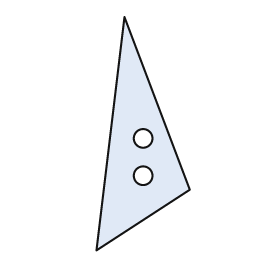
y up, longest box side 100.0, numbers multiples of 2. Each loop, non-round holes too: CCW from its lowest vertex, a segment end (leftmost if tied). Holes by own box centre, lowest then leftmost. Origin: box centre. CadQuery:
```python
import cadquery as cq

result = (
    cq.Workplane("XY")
    .moveTo(-20.0, -50.0)
    .lineTo(20.0, -24.0)
    .lineTo(-8.0, 50.0)
    .close()
    .moveTo(0.0, -18.0)
    .circle(4.0)
    .moveTo(0.0, -2.0)
    .circle(4.0)
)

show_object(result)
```